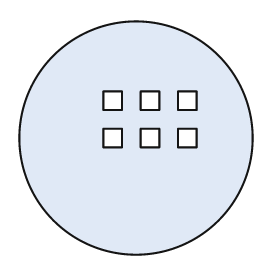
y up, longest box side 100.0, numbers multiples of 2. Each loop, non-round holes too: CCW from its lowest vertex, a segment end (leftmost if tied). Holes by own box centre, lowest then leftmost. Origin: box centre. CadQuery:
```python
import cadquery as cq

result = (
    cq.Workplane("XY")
    .moveTo(0.0, 0.0)
    .circle(50.0)
    .moveTo(-14.0, -4.0)
    .lineTo(-6.0, -4.0)
    .lineTo(-6.0, 4.0)
    .lineTo(-14.0, 4.0)
    .close()
    .moveTo(2.0, -4.0)
    .lineTo(10.0, -4.0)
    .lineTo(10.0, 4.0)
    .lineTo(2.0, 4.0)
    .close()
    .moveTo(18.0, -4.0)
    .lineTo(26.0, -4.0)
    .lineTo(26.0, 4.0)
    .lineTo(18.0, 4.0)
    .close()
    .moveTo(-14.0, 12.0)
    .lineTo(-6.0, 12.0)
    .lineTo(-6.0, 20.0)
    .lineTo(-14.0, 20.0)
    .close()
    .moveTo(2.0, 12.0)
    .lineTo(10.0, 12.0)
    .lineTo(10.0, 20.0)
    .lineTo(2.0, 20.0)
    .close()
    .moveTo(18.0, 12.0)
    .lineTo(26.0, 12.0)
    .lineTo(26.0, 20.0)
    .lineTo(18.0, 20.0)
    .close()
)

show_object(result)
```